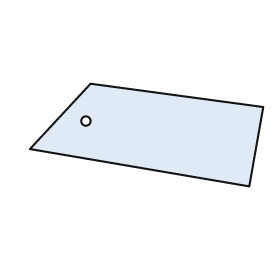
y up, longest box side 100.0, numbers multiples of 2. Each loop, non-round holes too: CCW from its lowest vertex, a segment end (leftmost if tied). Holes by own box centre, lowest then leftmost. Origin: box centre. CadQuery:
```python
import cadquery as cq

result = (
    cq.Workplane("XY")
    .moveTo(44.0, -22.0)
    .lineTo(50.0, 12.0)
    .lineTo(-24.0, 22.0)
    .lineTo(-50.0, -6.0)
    .close()
    .moveTo(-26.0, 6.0)
    .circle(2.0)
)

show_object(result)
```